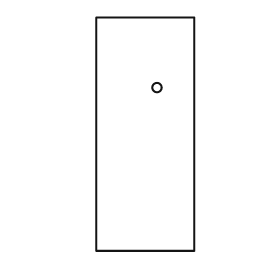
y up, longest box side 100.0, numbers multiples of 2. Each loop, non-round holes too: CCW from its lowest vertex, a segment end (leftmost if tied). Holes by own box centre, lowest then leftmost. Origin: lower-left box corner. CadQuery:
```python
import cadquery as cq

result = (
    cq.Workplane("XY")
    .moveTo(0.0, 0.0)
    .lineTo(42.0, 0.0)
    .lineTo(42.0, 100.0)
    .lineTo(0.0, 100.0)
    .close()
    .moveTo(26.0, 70.0)
    .circle(2.0)
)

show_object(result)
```